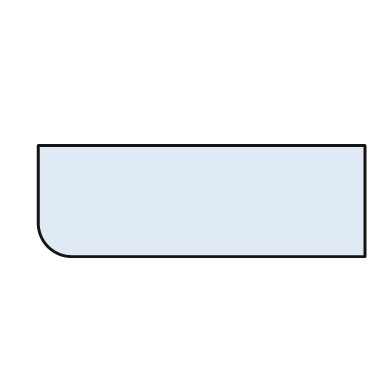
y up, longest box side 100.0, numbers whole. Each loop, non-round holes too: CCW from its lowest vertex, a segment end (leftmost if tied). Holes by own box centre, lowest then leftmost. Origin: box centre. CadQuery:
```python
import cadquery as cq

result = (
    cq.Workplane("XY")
    .moveTo(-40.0, -17.0)
    .lineTo(50.0, -17.0)
    .lineTo(50.0, 17.0)
    .lineTo(-50.0, 17.0)
    .lineTo(-50.0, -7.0)
    .threePointArc((-47.0, -14.0), (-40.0, -17.0))
    .close()
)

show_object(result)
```